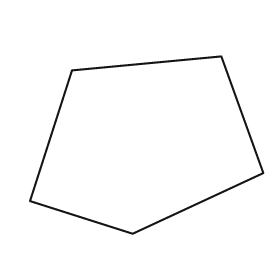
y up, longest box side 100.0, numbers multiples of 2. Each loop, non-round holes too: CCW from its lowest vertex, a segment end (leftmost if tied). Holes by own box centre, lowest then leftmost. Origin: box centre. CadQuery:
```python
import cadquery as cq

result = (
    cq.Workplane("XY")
    .moveTo(-6.0, -38.0)
    .lineTo(50.0, -12.0)
    .lineTo(32.0, 38.0)
    .lineTo(-32.0, 32.0)
    .lineTo(-50.0, -24.0)
    .close()
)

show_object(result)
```